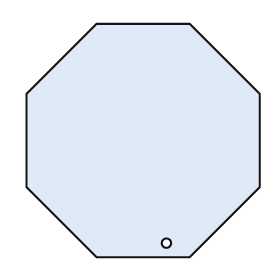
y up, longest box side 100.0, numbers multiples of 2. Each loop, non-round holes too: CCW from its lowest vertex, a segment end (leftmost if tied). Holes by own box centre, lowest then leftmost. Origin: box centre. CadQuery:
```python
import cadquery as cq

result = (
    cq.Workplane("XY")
    .moveTo(-20.0, -50.0)
    .lineTo(20.0, -50.0)
    .lineTo(50.0, -20.0)
    .lineTo(50.0, 20.0)
    .lineTo(20.0, 50.0)
    .lineTo(-20.0, 50.0)
    .lineTo(-50.0, 20.0)
    .lineTo(-50.0, -20.0)
    .close()
    .moveTo(10.0, -44.0)
    .circle(2.0)
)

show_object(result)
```